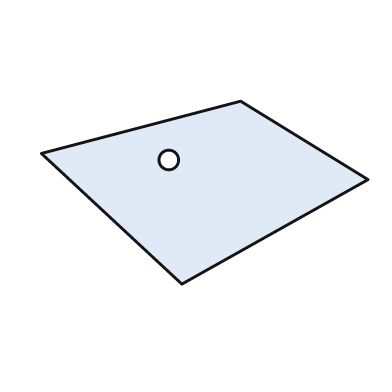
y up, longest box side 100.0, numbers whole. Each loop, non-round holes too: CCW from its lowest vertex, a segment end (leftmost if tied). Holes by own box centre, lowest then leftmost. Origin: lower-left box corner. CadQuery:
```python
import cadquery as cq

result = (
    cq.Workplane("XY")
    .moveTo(43.0, 0.0)
    .lineTo(100.0, 32.0)
    .lineTo(61.0, 56.0)
    .lineTo(0.0, 40.0)
    .close()
    .moveTo(39.0, 38.0)
    .circle(3.0)
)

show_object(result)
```